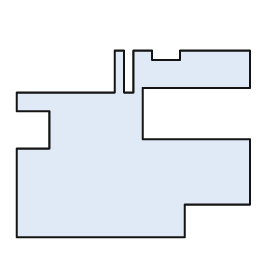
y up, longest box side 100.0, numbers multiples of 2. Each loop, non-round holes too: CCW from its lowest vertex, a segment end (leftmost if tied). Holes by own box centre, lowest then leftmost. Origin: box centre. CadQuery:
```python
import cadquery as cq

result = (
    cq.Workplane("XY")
    .moveTo(-50.0, -40.0)
    .lineTo(22.0, -40.0)
    .lineTo(22.0, -26.0)
    .lineTo(50.0, -26.0)
    .lineTo(50.0, 2.0)
    .lineTo(4.0, 2.0)
    .lineTo(4.0, 24.0)
    .lineTo(50.0, 24.0)
    .lineTo(50.0, 40.0)
    .lineTo(20.0, 40.0)
    .lineTo(20.0, 36.0)
    .lineTo(8.0, 36.0)
    .lineTo(8.0, 40.0)
    .lineTo(0.0, 40.0)
    .lineTo(0.0, 22.0)
    .lineTo(-4.0, 22.0)
    .lineTo(-4.0, 40.0)
    .lineTo(-8.0, 40.0)
    .lineTo(-8.0, 22.0)
    .lineTo(-50.0, 22.0)
    .lineTo(-50.0, 14.0)
    .lineTo(-36.0, 14.0)
    .lineTo(-36.0, -2.0)
    .lineTo(-50.0, -2.0)
    .close()
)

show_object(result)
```